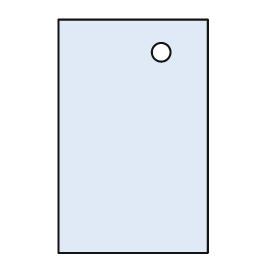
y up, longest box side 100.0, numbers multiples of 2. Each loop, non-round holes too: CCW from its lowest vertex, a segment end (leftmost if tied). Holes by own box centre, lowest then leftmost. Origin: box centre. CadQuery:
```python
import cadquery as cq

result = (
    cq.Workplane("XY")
    .moveTo(-32.0, -50.0)
    .lineTo(32.0, -50.0)
    .lineTo(32.0, 50.0)
    .lineTo(-32.0, 50.0)
    .close()
    .moveTo(12.0, 36.0)
    .circle(4.0)
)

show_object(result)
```